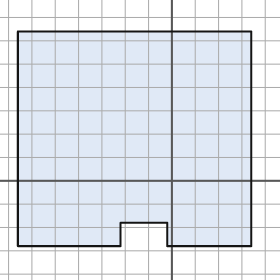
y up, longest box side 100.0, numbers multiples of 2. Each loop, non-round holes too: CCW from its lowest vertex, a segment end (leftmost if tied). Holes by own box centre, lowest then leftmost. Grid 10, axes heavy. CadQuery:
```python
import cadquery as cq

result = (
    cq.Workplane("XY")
    .moveTo(-66.0, -28.0)
    .lineTo(-22.0, -28.0)
    .lineTo(-22.0, -18.0)
    .lineTo(-2.0, -18.0)
    .lineTo(-2.0, -28.0)
    .lineTo(34.0, -28.0)
    .lineTo(34.0, 64.0)
    .lineTo(-66.0, 64.0)
    .close()
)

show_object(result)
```